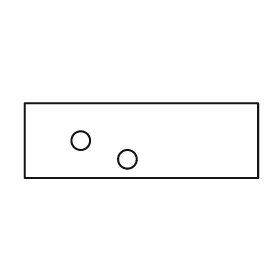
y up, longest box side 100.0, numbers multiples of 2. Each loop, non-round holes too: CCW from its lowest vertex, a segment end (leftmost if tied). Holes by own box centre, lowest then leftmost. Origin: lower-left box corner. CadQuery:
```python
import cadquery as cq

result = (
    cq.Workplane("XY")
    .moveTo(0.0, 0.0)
    .lineTo(100.0, 0.0)
    .lineTo(100.0, 32.0)
    .lineTo(0.0, 32.0)
    .close()
    .moveTo(44.0, 8.0)
    .circle(4.0)
    .moveTo(24.0, 16.0)
    .circle(4.0)
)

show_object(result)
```